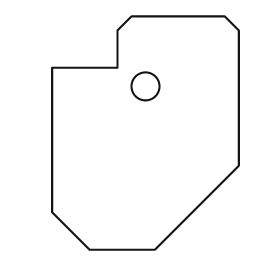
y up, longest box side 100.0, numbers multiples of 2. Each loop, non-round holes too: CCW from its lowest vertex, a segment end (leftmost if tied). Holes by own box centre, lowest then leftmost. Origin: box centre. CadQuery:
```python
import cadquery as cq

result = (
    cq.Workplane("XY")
    .moveTo(-24.0, -50.0)
    .lineTo(4.0, -50.0)
    .lineTo(40.0, -14.0)
    .lineTo(40.0, 44.0)
    .lineTo(34.0, 50.0)
    .lineTo(-6.0, 50.0)
    .lineTo(-12.0, 44.0)
    .lineTo(-12.0, 28.0)
    .lineTo(-40.0, 28.0)
    .lineTo(-40.0, -34.0)
    .close()
    .moveTo(0.0, 20.0)
    .circle(6.0)
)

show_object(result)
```